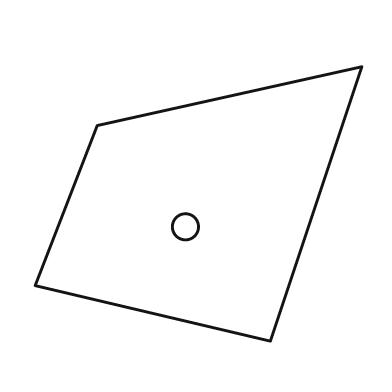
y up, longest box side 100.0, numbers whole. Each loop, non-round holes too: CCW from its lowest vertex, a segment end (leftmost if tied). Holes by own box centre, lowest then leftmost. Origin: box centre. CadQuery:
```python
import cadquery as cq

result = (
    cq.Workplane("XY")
    .moveTo(22.0, -42.0)
    .lineTo(50.0, 42.0)
    .lineTo(-31.0, 24.0)
    .lineTo(-50.0, -25.0)
    .close()
    .moveTo(-4.0, -7.0)
    .circle(4.0)
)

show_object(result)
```